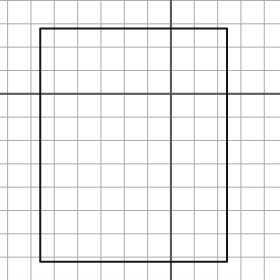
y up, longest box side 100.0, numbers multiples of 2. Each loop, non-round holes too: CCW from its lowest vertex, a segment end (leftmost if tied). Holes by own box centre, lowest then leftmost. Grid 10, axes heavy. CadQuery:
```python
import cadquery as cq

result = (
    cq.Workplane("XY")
    .moveTo(-56.0, -72.0)
    .lineTo(24.0, -72.0)
    .lineTo(24.0, 28.0)
    .lineTo(-56.0, 28.0)
    .close()
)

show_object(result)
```